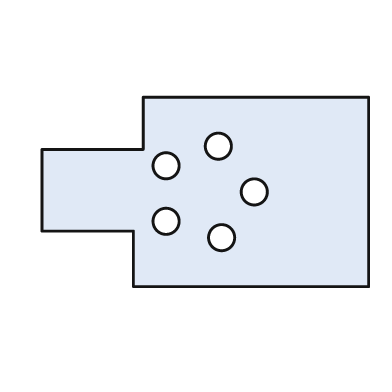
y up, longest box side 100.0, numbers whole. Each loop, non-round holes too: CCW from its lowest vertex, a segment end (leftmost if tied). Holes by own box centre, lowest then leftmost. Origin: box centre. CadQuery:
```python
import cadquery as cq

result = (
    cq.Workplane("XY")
    .moveTo(-22.0, -29.0)
    .lineTo(50.0, -29.0)
    .lineTo(50.0, 29.0)
    .lineTo(-19.0, 29.0)
    .lineTo(-19.0, 13.0)
    .lineTo(-50.0, 13.0)
    .lineTo(-50.0, -12.0)
    .lineTo(-22.0, -12.0)
    .close()
    .moveTo(5.0, -14.0)
    .circle(4.0)
    .moveTo(-12.0, -9.0)
    .circle(4.0)
    .moveTo(15.0, 0.0)
    .circle(4.0)
    .moveTo(-12.0, 8.0)
    .circle(4.0)
    .moveTo(4.0, 14.0)
    .circle(4.0)
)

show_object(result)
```